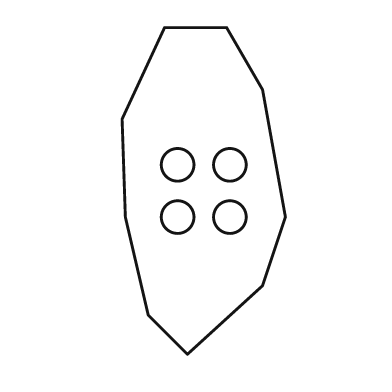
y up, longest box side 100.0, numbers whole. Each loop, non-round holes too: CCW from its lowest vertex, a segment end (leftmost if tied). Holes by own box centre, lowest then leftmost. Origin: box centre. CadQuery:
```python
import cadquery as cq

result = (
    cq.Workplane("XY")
    .moveTo(-5.0, -50.0)
    .lineTo(18.0, -29.0)
    .lineTo(25.0, -8.0)
    .lineTo(18.0, 31.0)
    .lineTo(7.0, 50.0)
    .lineTo(-12.0, 50.0)
    .lineTo(-25.0, 22.0)
    .lineTo(-24.0, -8.0)
    .lineTo(-17.0, -38.0)
    .close()
    .moveTo(-8.0, -8.0)
    .circle(5.0)
    .moveTo(8.0, -8.0)
    .circle(5.0)
    .moveTo(-8.0, 8.0)
    .circle(5.0)
    .moveTo(8.0, 8.0)
    .circle(5.0)
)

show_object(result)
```